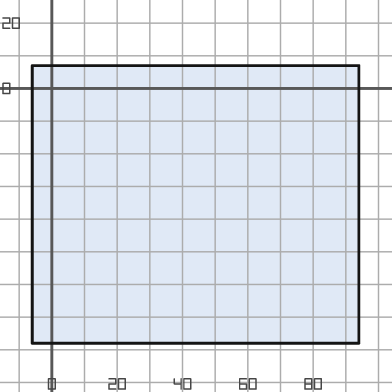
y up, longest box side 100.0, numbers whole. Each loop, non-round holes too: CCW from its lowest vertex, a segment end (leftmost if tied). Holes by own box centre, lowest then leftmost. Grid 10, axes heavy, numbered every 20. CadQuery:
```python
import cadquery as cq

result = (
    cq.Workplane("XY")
    .moveTo(-6.0, -78.0)
    .lineTo(94.0, -78.0)
    .lineTo(94.0, 7.0)
    .lineTo(-6.0, 7.0)
    .close()
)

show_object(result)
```